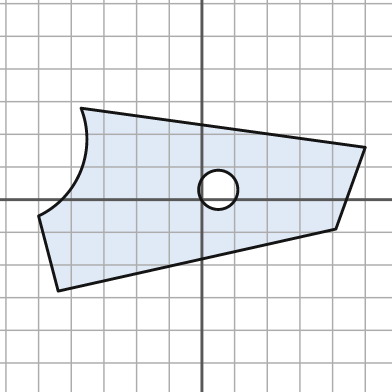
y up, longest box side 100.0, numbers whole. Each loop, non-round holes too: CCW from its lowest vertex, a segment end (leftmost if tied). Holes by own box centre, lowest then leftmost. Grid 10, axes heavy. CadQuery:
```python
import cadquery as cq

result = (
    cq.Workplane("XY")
    .moveTo(-44.0, -28.0)
    .lineTo(41.0, -9.0)
    .lineTo(50.0, 16.0)
    .lineTo(-37.0, 28.0)
    .threePointArc((-37.0, 9.0), (-50.0, -5.0))
    .close()
    .moveTo(5.0, 3.0)
    .circle(6.0)
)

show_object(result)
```